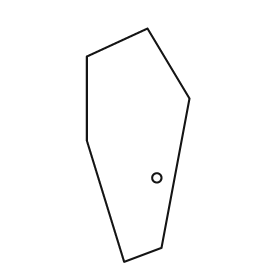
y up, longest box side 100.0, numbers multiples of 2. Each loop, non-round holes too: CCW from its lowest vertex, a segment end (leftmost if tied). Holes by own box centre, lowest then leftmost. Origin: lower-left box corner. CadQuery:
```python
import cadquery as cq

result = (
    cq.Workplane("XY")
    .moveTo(16.0, 0.0)
    .lineTo(32.0, 6.0)
    .lineTo(44.0, 70.0)
    .lineTo(26.0, 100.0)
    .lineTo(0.0, 88.0)
    .lineTo(0.0, 52.0)
    .close()
    .moveTo(30.0, 36.0)
    .circle(2.0)
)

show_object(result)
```